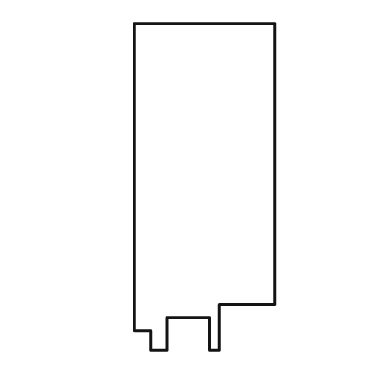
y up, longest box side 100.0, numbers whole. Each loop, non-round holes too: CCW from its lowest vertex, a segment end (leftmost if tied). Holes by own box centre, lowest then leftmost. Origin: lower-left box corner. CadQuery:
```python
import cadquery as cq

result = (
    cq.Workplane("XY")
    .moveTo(5.0, 0.0)
    .lineTo(10.0, 0.0)
    .lineTo(10.0, 10.0)
    .lineTo(23.0, 10.0)
    .lineTo(23.0, 0.0)
    .lineTo(26.0, 0.0)
    .lineTo(26.0, 14.0)
    .lineTo(43.0, 14.0)
    .lineTo(43.0, 100.0)
    .lineTo(0.0, 100.0)
    .lineTo(0.0, 6.0)
    .lineTo(5.0, 6.0)
    .close()
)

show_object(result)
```